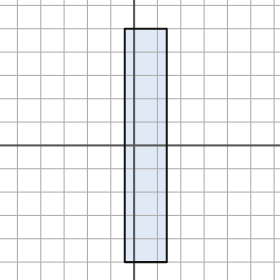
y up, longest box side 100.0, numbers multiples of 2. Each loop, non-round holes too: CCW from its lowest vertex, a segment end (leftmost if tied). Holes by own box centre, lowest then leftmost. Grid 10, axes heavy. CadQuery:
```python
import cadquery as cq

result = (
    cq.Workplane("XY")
    .moveTo(-4.0, -50.0)
    .lineTo(14.0, -50.0)
    .lineTo(14.0, 50.0)
    .lineTo(-4.0, 50.0)
    .close()
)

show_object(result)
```